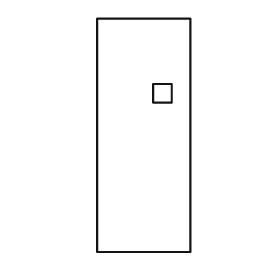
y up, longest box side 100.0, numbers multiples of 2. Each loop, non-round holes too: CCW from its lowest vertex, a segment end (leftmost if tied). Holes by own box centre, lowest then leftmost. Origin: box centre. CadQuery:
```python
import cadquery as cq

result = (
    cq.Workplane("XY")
    .moveTo(-20.0, -50.0)
    .lineTo(20.0, -50.0)
    .lineTo(20.0, 50.0)
    .lineTo(-20.0, 50.0)
    .close()
    .moveTo(4.0, 14.0)
    .lineTo(12.0, 14.0)
    .lineTo(12.0, 22.0)
    .lineTo(4.0, 22.0)
    .close()
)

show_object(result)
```